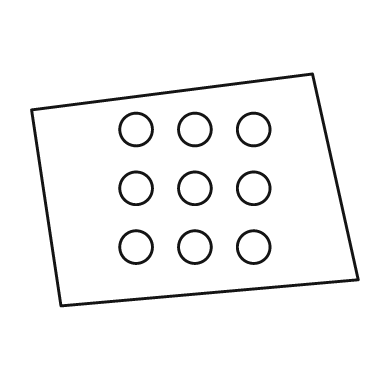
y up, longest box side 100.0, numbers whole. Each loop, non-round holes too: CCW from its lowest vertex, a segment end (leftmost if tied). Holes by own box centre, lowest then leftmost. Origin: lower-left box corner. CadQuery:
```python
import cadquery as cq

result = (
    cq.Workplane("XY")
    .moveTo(9.0, 0.0)
    .lineTo(100.0, 8.0)
    .lineTo(86.0, 71.0)
    .lineTo(0.0, 60.0)
    .close()
    .moveTo(32.0, 18.0)
    .circle(5.0)
    .moveTo(50.0, 18.0)
    .circle(5.0)
    .moveTo(68.0, 18.0)
    .circle(5.0)
    .moveTo(32.0, 36.0)
    .circle(5.0)
    .moveTo(50.0, 36.0)
    .circle(5.0)
    .moveTo(68.0, 36.0)
    .circle(5.0)
    .moveTo(32.0, 54.0)
    .circle(5.0)
    .moveTo(50.0, 54.0)
    .circle(5.0)
    .moveTo(68.0, 54.0)
    .circle(5.0)
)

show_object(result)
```